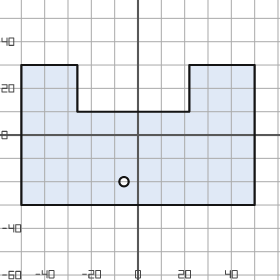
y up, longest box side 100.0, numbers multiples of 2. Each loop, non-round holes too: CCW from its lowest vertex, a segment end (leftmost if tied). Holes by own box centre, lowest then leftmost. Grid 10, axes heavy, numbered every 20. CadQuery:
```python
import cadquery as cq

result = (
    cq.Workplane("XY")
    .moveTo(-50.0, -30.0)
    .lineTo(50.0, -30.0)
    .lineTo(50.0, 30.0)
    .lineTo(22.0, 30.0)
    .lineTo(22.0, 10.0)
    .lineTo(-26.0, 10.0)
    .lineTo(-26.0, 30.0)
    .lineTo(-50.0, 30.0)
    .close()
    .moveTo(-6.0, -20.0)
    .circle(2.0)
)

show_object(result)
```